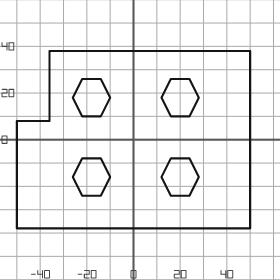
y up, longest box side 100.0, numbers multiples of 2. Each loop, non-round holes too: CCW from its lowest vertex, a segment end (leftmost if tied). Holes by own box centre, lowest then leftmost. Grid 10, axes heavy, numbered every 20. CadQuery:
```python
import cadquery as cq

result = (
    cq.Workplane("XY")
    .moveTo(-50.0, -38.0)
    .lineTo(50.0, -38.0)
    .lineTo(50.0, 38.0)
    .lineTo(-36.0, 38.0)
    .lineTo(-36.0, 8.0)
    .lineTo(-50.0, 8.0)
    .close()
    .moveTo(-22.0, -24.0)
    .lineTo(-14.0, -24.0)
    .lineTo(-10.0, -16.0)
    .lineTo(-14.0, -8.0)
    .lineTo(-22.0, -8.0)
    .lineTo(-26.0, -16.0)
    .close()
    .moveTo(16.0, -24.0)
    .lineTo(24.0, -24.0)
    .lineTo(28.0, -16.0)
    .lineTo(24.0, -8.0)
    .lineTo(16.0, -8.0)
    .lineTo(12.0, -16.0)
    .close()
    .moveTo(-22.0, 10.0)
    .lineTo(-14.0, 10.0)
    .lineTo(-10.0, 18.0)
    .lineTo(-14.0, 26.0)
    .lineTo(-22.0, 26.0)
    .lineTo(-26.0, 18.0)
    .close()
    .moveTo(16.0, 10.0)
    .lineTo(24.0, 10.0)
    .lineTo(28.0, 18.0)
    .lineTo(24.0, 26.0)
    .lineTo(16.0, 26.0)
    .lineTo(12.0, 18.0)
    .close()
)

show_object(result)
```